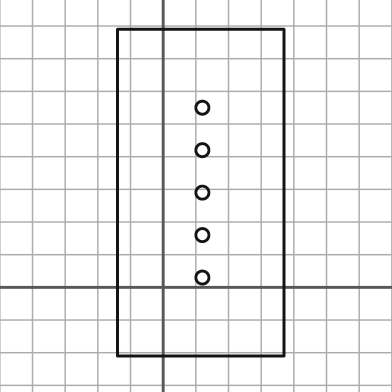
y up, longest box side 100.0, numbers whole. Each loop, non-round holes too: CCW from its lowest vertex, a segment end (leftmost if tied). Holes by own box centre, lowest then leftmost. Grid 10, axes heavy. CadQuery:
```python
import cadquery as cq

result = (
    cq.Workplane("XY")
    .moveTo(-14.0, -21.0)
    .lineTo(37.0, -21.0)
    .lineTo(37.0, 79.0)
    .lineTo(-14.0, 79.0)
    .close()
    .moveTo(12.0, 3.0)
    .circle(2.0)
    .moveTo(12.0, 16.0)
    .circle(2.0)
    .moveTo(12.0, 29.0)
    .circle(2.0)
    .moveTo(12.0, 42.0)
    .circle(2.0)
    .moveTo(12.0, 55.0)
    .circle(2.0)
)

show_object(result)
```